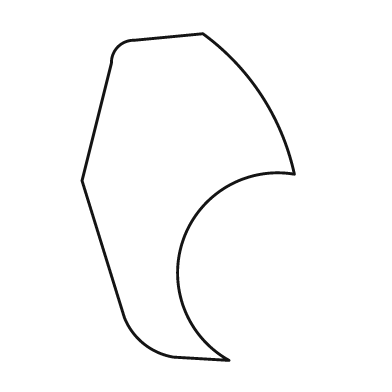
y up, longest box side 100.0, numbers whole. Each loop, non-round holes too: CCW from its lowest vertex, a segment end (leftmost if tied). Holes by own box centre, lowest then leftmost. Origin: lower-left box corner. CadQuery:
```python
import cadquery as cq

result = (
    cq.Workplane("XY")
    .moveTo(45.0, 0.0)
    .threePointArc((31.0, 37.0), (65.0, 57.0))
    .threePointArc((55.0, 81.0), (37.0, 100.0))
    .lineTo(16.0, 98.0)
    .threePointArc((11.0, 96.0), (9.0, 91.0))
    .lineTo(0.0, 55.0)
    .lineTo(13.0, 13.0)
    .threePointArc((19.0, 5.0), (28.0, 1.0))
    .close()
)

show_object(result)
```